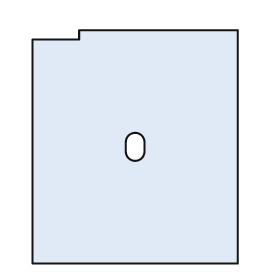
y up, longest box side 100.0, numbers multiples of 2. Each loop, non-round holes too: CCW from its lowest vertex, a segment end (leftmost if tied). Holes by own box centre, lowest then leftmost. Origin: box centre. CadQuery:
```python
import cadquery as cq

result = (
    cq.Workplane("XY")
    .moveTo(-44.0, -50.0)
    .lineTo(44.0, -50.0)
    .lineTo(44.0, 50.0)
    .lineTo(-24.0, 50.0)
    .lineTo(-24.0, 46.0)
    .lineTo(-44.0, 46.0)
    .close()
    .moveTo(-4.0, -2.0)
    .threePointArc((0.0, -6.0), (4.0, -2.0))
    .lineTo(4.0, 2.0)
    .threePointArc((0.0, 6.0), (-4.0, 2.0))
    .close()
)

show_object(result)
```